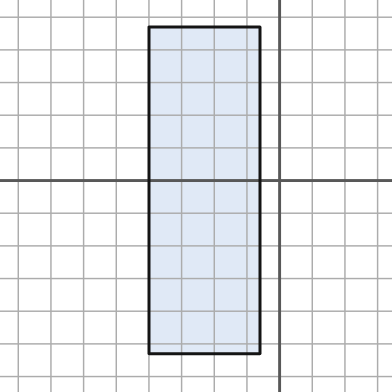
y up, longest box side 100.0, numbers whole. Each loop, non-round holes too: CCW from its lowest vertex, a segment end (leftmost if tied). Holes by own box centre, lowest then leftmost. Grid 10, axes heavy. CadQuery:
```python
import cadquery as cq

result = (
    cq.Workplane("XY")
    .moveTo(-40.0, -53.0)
    .lineTo(-6.0, -53.0)
    .lineTo(-6.0, 47.0)
    .lineTo(-40.0, 47.0)
    .close()
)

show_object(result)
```